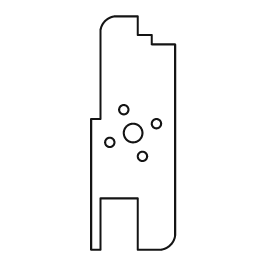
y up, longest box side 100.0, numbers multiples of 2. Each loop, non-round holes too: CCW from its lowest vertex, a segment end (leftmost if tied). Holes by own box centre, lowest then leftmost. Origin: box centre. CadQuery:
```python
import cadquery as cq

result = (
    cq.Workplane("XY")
    .moveTo(-18.0, -50.0)
    .lineTo(-14.0, -50.0)
    .lineTo(-14.0, -28.0)
    .lineTo(2.0, -28.0)
    .lineTo(2.0, -50.0)
    .lineTo(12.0, -50.0)
    .threePointArc((16.0, -48.0), (18.0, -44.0))
    .lineTo(18.0, 38.0)
    .lineTo(8.0, 38.0)
    .lineTo(8.0, 42.0)
    .lineTo(2.0, 42.0)
    .lineTo(2.0, 50.0)
    .lineTo(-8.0, 50.0)
    .threePointArc((-12.0, 48.0), (-14.0, 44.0))
    .lineTo(-14.0, 6.0)
    .lineTo(-18.0, 6.0)
    .close()
    .moveTo(4.0, -10.0)
    .circle(2.0)
    .moveTo(-10.0, -4.0)
    .circle(2.0)
    .moveTo(0.0, 0.0)
    .circle(4.0)
    .moveTo(10.0, 4.0)
    .circle(2.0)
    .moveTo(-4.0, 10.0)
    .circle(2.0)
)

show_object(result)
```